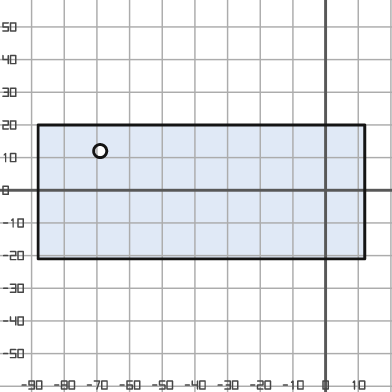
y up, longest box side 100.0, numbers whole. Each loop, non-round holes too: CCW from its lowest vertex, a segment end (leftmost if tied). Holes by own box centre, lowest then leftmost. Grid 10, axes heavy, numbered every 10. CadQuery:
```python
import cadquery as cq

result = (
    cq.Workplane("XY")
    .moveTo(-88.0, -21.0)
    .lineTo(12.0, -21.0)
    .lineTo(12.0, 20.0)
    .lineTo(-88.0, 20.0)
    .close()
    .moveTo(-69.0, 12.0)
    .circle(2.0)
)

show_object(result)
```